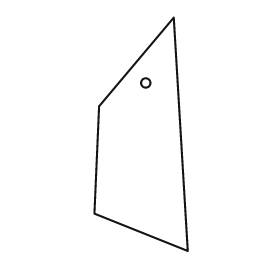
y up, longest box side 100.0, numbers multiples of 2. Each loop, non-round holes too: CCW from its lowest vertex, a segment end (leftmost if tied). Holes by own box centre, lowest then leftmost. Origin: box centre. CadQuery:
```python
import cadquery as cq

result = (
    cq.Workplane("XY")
    .moveTo(20.0, -50.0)
    .lineTo(14.0, 50.0)
    .lineTo(-18.0, 12.0)
    .lineTo(-20.0, -34.0)
    .close()
    .moveTo(2.0, 22.0)
    .circle(2.0)
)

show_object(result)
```